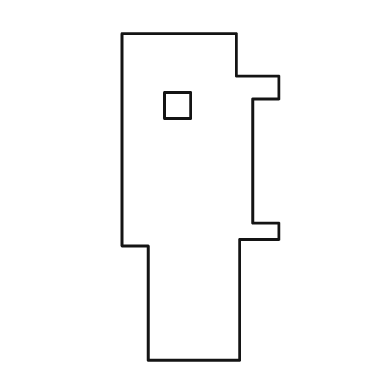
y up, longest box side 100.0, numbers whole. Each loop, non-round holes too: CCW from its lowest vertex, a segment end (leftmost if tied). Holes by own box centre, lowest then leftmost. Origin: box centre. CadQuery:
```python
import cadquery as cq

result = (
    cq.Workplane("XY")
    .moveTo(-16.0, -50.0)
    .lineTo(12.0, -50.0)
    .lineTo(12.0, -13.0)
    .lineTo(24.0, -13.0)
    .lineTo(24.0, -8.0)
    .lineTo(16.0, -8.0)
    .lineTo(16.0, 30.0)
    .lineTo(24.0, 30.0)
    .lineTo(24.0, 37.0)
    .lineTo(11.0, 37.0)
    .lineTo(11.0, 50.0)
    .lineTo(-24.0, 50.0)
    .lineTo(-24.0, -15.0)
    .lineTo(-16.0, -15.0)
    .close()
    .moveTo(-11.0, 24.0)
    .lineTo(-3.0, 24.0)
    .lineTo(-3.0, 32.0)
    .lineTo(-11.0, 32.0)
    .close()
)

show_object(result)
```